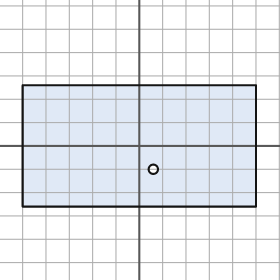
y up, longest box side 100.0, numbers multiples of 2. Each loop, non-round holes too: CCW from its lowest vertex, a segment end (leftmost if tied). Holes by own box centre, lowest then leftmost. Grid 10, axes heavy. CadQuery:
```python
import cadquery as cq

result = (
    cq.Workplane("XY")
    .moveTo(-50.0, -26.0)
    .lineTo(50.0, -26.0)
    .lineTo(50.0, 26.0)
    .lineTo(-50.0, 26.0)
    .close()
    .moveTo(6.0, -10.0)
    .circle(2.0)
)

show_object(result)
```